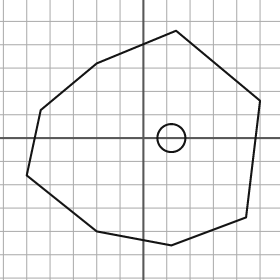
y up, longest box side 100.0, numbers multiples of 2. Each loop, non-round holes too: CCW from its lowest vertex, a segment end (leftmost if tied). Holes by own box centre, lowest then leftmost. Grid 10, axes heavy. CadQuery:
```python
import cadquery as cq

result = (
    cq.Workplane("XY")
    .moveTo(12.0, -46.0)
    .lineTo(44.0, -34.0)
    .lineTo(50.0, 16.0)
    .lineTo(14.0, 46.0)
    .lineTo(-20.0, 32.0)
    .lineTo(-44.0, 12.0)
    .lineTo(-50.0, -16.0)
    .lineTo(-20.0, -40.0)
    .close()
    .moveTo(12.0, 0.0)
    .circle(6.0)
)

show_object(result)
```